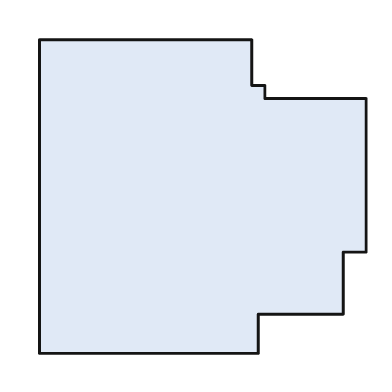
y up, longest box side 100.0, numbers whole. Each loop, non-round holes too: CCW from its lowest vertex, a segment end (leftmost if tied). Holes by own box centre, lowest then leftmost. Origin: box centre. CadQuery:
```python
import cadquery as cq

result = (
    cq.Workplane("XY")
    .moveTo(-50.0, -48.0)
    .lineTo(17.0, -48.0)
    .lineTo(17.0, -36.0)
    .lineTo(43.0, -36.0)
    .lineTo(43.0, -17.0)
    .lineTo(50.0, -17.0)
    .lineTo(50.0, 30.0)
    .lineTo(19.0, 30.0)
    .lineTo(19.0, 34.0)
    .lineTo(15.0, 34.0)
    .lineTo(15.0, 48.0)
    .lineTo(-50.0, 48.0)
    .close()
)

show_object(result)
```